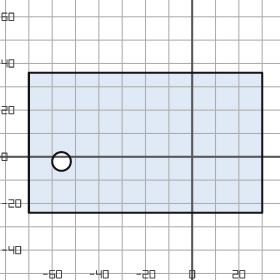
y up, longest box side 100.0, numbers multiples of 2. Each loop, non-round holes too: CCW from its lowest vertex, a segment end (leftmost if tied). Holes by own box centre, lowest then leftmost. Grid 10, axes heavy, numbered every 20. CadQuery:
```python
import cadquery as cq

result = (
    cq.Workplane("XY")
    .moveTo(-70.0, -24.0)
    .lineTo(30.0, -24.0)
    .lineTo(30.0, 36.0)
    .lineTo(-70.0, 36.0)
    .close()
    .moveTo(-56.0, -2.0)
    .circle(4.0)
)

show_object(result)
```